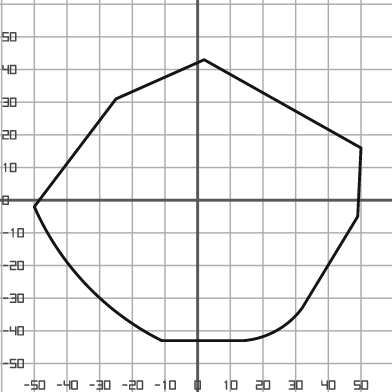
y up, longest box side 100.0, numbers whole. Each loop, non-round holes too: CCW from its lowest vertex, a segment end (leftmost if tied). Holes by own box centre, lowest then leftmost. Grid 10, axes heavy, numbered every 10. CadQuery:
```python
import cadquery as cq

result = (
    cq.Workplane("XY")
    .moveTo(-11.0, -43.0)
    .lineTo(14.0, -43.0)
    .threePointArc((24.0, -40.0), (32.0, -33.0))
    .lineTo(49.0, -5.0)
    .lineTo(50.0, 16.0)
    .lineTo(2.0, 43.0)
    .lineTo(-25.0, 31.0)
    .lineTo(-50.0, -2.0)
    .threePointArc((-34.0, -26.0), (-11.0, -43.0))
    .close()
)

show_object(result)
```